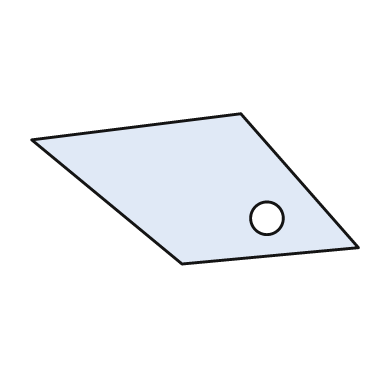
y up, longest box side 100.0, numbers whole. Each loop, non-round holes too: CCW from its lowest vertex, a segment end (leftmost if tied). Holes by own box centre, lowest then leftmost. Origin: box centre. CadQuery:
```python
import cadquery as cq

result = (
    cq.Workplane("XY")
    .moveTo(-4.0, -23.0)
    .lineTo(50.0, -18.0)
    .lineTo(14.0, 23.0)
    .lineTo(-50.0, 15.0)
    .close()
    .moveTo(22.0, -9.0)
    .circle(5.0)
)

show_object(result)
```